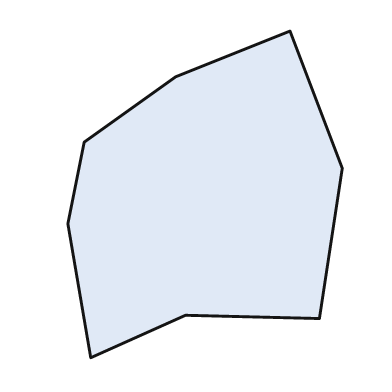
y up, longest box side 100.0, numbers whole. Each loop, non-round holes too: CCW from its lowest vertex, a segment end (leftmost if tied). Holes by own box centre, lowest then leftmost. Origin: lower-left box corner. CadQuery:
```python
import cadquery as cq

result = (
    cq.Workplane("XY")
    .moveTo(7.0, 0.0)
    .lineTo(36.0, 13.0)
    .lineTo(77.0, 12.0)
    .lineTo(84.0, 58.0)
    .lineTo(68.0, 100.0)
    .lineTo(33.0, 86.0)
    .lineTo(5.0, 66.0)
    .lineTo(0.0, 41.0)
    .close()
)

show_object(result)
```